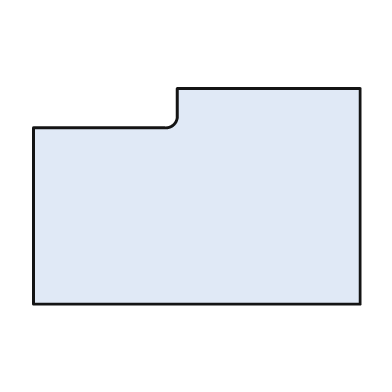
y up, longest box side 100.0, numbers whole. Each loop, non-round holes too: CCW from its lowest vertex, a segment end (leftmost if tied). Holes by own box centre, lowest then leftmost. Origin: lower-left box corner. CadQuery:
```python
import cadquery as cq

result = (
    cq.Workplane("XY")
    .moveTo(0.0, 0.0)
    .lineTo(100.0, 0.0)
    .lineTo(100.0, 66.0)
    .lineTo(44.0, 66.0)
    .lineTo(44.0, 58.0)
    .threePointArc((43.0, 55.0), (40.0, 54.0))
    .lineTo(0.0, 54.0)
    .close()
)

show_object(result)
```